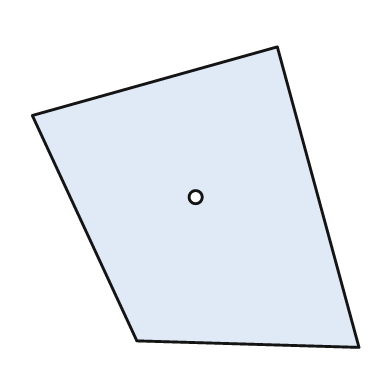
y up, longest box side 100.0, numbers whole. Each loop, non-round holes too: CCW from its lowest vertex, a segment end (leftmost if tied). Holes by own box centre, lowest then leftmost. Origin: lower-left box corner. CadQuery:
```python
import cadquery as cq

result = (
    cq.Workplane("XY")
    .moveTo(100.0, 0.0)
    .lineTo(75.0, 92.0)
    .lineTo(0.0, 71.0)
    .lineTo(32.0, 2.0)
    .close()
    .moveTo(50.0, 46.0)
    .circle(2.0)
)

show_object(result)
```